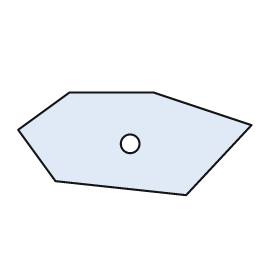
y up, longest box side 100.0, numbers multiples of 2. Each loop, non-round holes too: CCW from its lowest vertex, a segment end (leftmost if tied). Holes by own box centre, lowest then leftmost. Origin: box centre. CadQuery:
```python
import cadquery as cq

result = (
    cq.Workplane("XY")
    .moveTo(22.0, -22.0)
    .lineTo(50.0, 8.0)
    .lineTo(8.0, 22.0)
    .lineTo(-28.0, 22.0)
    .lineTo(-50.0, 6.0)
    .lineTo(-34.0, -16.0)
    .close()
    .moveTo(-2.0, 0.0)
    .circle(4.0)
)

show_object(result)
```